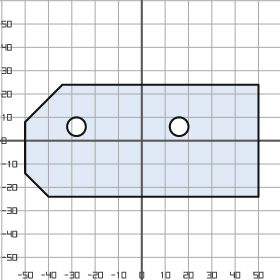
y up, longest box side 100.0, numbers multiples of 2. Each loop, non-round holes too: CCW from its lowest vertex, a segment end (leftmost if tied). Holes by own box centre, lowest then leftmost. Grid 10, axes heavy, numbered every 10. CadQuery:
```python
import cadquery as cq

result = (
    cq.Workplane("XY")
    .moveTo(-40.0, -24.0)
    .lineTo(50.0, -24.0)
    .lineTo(50.0, 24.0)
    .lineTo(-34.0, 24.0)
    .lineTo(-50.0, 8.0)
    .lineTo(-50.0, -14.0)
    .close()
    .moveTo(-28.0, 6.0)
    .circle(4.0)
    .moveTo(16.0, 6.0)
    .circle(4.0)
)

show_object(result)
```